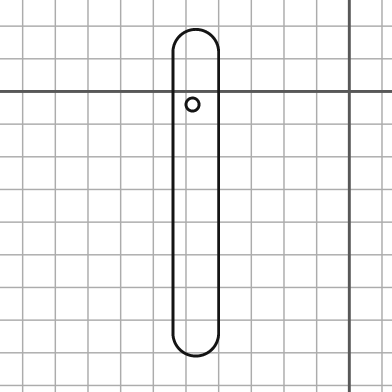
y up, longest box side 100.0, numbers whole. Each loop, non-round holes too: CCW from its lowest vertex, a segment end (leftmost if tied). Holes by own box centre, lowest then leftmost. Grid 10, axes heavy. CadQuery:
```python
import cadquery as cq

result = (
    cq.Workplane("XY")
    .moveTo(-54.0, -74.0)
    .threePointArc((-47.0, -81.0), (-40.0, -74.0))
    .lineTo(-40.0, 12.0)
    .threePointArc((-47.0, 19.0), (-54.0, 12.0))
    .close()
    .moveTo(-48.0, -4.0)
    .circle(2.0)
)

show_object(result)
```